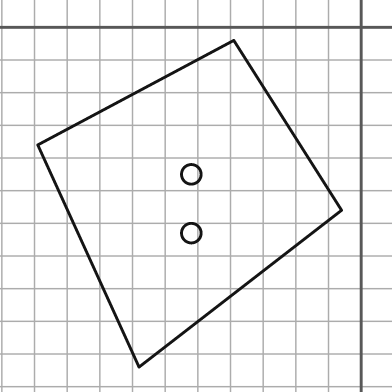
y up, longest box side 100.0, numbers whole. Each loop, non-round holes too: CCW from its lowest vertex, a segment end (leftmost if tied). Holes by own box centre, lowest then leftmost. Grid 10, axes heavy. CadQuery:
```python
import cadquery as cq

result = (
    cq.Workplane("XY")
    .moveTo(-68.0, -104.0)
    .lineTo(-6.0, -56.0)
    .lineTo(-39.0, -4.0)
    .lineTo(-99.0, -36.0)
    .close()
    .moveTo(-52.0, -63.0)
    .circle(3.0)
    .moveTo(-52.0, -45.0)
    .circle(3.0)
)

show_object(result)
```